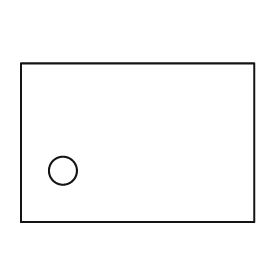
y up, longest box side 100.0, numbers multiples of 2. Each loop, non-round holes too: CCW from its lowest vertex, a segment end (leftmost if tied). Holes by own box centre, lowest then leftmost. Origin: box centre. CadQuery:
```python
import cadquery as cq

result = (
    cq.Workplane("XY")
    .moveTo(-50.0, -34.0)
    .lineTo(50.0, -34.0)
    .lineTo(50.0, 34.0)
    .lineTo(-50.0, 34.0)
    .close()
    .moveTo(-32.0, -12.0)
    .circle(6.0)
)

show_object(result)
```